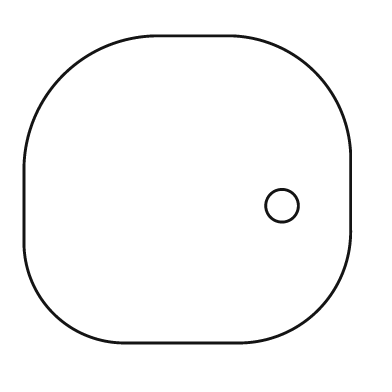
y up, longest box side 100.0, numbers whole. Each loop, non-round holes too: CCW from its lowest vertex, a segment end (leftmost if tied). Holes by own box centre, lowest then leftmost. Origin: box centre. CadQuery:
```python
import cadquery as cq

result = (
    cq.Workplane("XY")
    .moveTo(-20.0, -47.0)
    .lineTo(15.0, -47.0)
    .threePointArc((40.0, -37.0), (50.0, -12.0))
    .lineTo(50.0, 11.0)
    .threePointArc((39.0, 36.0), (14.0, 47.0))
    .lineTo(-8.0, 47.0)
    .threePointArc((-38.0, 35.0), (-50.0, 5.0))
    .lineTo(-50.0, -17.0)
    .threePointArc((-41.0, -38.0), (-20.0, -47.0))
    .close()
    .moveTo(29.0, -5.0)
    .circle(5.0)
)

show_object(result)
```